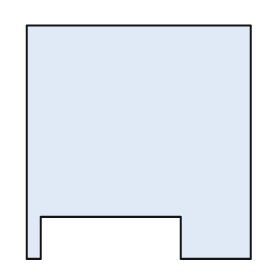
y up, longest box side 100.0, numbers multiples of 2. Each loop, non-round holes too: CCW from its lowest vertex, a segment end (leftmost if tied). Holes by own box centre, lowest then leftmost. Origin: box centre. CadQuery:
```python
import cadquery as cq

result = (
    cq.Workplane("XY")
    .moveTo(-48.0, -50.0)
    .lineTo(-42.0, -50.0)
    .lineTo(-42.0, -32.0)
    .lineTo(18.0, -32.0)
    .lineTo(18.0, -50.0)
    .lineTo(48.0, -50.0)
    .lineTo(48.0, 50.0)
    .lineTo(-48.0, 50.0)
    .close()
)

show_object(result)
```